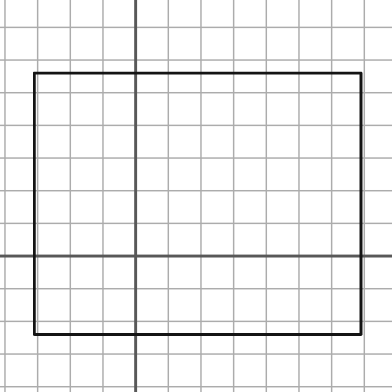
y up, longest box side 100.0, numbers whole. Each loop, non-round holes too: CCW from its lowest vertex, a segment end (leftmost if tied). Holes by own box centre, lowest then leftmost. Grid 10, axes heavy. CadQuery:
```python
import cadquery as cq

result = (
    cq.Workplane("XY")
    .moveTo(-31.0, -24.0)
    .lineTo(69.0, -24.0)
    .lineTo(69.0, 56.0)
    .lineTo(-31.0, 56.0)
    .close()
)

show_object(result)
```